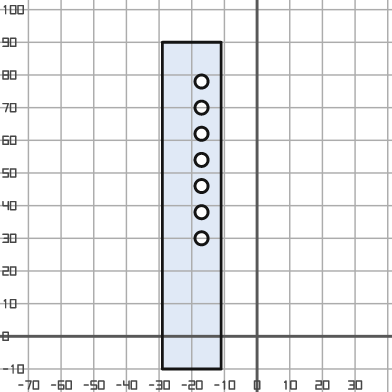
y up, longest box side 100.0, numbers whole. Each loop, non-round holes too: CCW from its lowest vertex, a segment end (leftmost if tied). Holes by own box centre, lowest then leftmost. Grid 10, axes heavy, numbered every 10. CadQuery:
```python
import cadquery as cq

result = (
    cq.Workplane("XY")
    .moveTo(-29.0, -10.0)
    .lineTo(-11.0, -10.0)
    .lineTo(-11.0, 90.0)
    .lineTo(-29.0, 90.0)
    .close()
    .moveTo(-17.0, 30.0)
    .circle(2.0)
    .moveTo(-17.0, 38.0)
    .circle(2.0)
    .moveTo(-17.0, 46.0)
    .circle(2.0)
    .moveTo(-17.0, 54.0)
    .circle(2.0)
    .moveTo(-17.0, 62.0)
    .circle(2.0)
    .moveTo(-17.0, 70.0)
    .circle(2.0)
    .moveTo(-17.0, 78.0)
    .circle(2.0)
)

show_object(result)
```